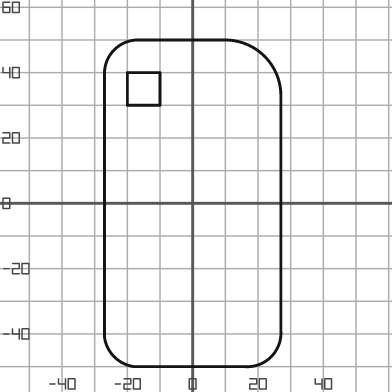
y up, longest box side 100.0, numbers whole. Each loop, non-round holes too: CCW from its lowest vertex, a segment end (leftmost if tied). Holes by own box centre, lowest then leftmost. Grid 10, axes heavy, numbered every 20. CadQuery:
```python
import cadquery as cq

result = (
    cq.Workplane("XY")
    .moveTo(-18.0, -50.0)
    .lineTo(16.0, -50.0)
    .threePointArc((24.0, -47.0), (27.0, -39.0))
    .lineTo(27.0, 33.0)
    .threePointArc((22.0, 45.0), (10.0, 50.0))
    .lineTo(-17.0, 50.0)
    .threePointArc((-24.0, 47.0), (-27.0, 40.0))
    .lineTo(-27.0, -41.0)
    .threePointArc((-24.0, -47.0), (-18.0, -50.0))
    .close()
    .moveTo(-20.0, 30.0)
    .lineTo(-10.0, 30.0)
    .lineTo(-10.0, 40.0)
    .lineTo(-20.0, 40.0)
    .close()
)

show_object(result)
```